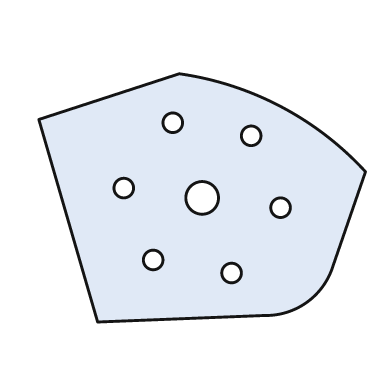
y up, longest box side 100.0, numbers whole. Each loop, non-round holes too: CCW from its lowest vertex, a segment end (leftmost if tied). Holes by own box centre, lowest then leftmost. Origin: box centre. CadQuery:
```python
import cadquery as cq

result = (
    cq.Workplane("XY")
    .moveTo(-32.0, -38.0)
    .lineTo(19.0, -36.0)
    .threePointArc((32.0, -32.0), (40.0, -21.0))
    .lineTo(50.0, 8.0)
    .threePointArc((24.0, 28.0), (-7.0, 38.0))
    .lineTo(-50.0, 24.0)
    .close()
    .moveTo(9.0, -23.0)
    .circle(3.0)
    .moveTo(-15.0, -19.0)
    .circle(3.0)
    .moveTo(24.0, -3.0)
    .circle(3.0)
    .moveTo(0.0, 0.0)
    .circle(5.0)
    .moveTo(-24.0, 3.0)
    .circle(3.0)
    .moveTo(15.0, 19.0)
    .circle(3.0)
    .moveTo(-9.0, 23.0)
    .circle(3.0)
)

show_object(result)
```